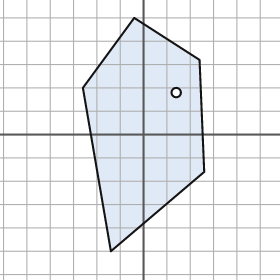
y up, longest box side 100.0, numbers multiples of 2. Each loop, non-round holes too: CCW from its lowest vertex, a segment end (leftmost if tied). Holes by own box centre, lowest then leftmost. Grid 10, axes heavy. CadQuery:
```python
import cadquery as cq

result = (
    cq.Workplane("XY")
    .moveTo(-14.0, -50.0)
    .lineTo(26.0, -16.0)
    .lineTo(24.0, 32.0)
    .lineTo(-4.0, 50.0)
    .lineTo(-26.0, 20.0)
    .close()
    .moveTo(14.0, 18.0)
    .circle(2.0)
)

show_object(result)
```